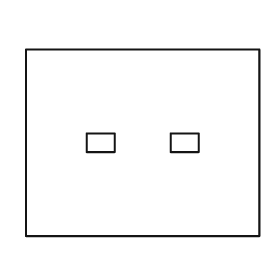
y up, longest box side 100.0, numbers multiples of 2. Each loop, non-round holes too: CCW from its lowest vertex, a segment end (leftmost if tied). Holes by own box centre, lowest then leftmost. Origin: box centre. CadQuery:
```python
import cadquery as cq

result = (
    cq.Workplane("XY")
    .moveTo(-50.0, -40.0)
    .lineTo(50.0, -40.0)
    .lineTo(50.0, 40.0)
    .lineTo(-50.0, 40.0)
    .close()
    .moveTo(-24.0, -4.0)
    .lineTo(-12.0, -4.0)
    .lineTo(-12.0, 4.0)
    .lineTo(-24.0, 4.0)
    .close()
    .moveTo(12.0, -4.0)
    .lineTo(24.0, -4.0)
    .lineTo(24.0, 4.0)
    .lineTo(12.0, 4.0)
    .close()
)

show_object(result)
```